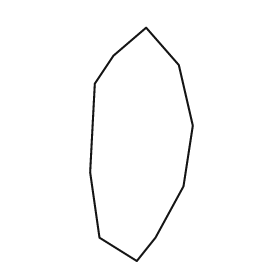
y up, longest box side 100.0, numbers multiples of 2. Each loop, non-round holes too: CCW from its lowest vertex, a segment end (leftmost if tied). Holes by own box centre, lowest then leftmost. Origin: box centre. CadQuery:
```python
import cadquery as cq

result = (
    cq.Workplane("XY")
    .moveTo(-2.0, -50.0)
    .lineTo(6.0, -40.0)
    .lineTo(18.0, -18.0)
    .lineTo(22.0, 8.0)
    .lineTo(16.0, 34.0)
    .lineTo(2.0, 50.0)
    .lineTo(-12.0, 38.0)
    .lineTo(-20.0, 26.0)
    .lineTo(-22.0, -12.0)
    .lineTo(-18.0, -40.0)
    .close()
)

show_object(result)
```